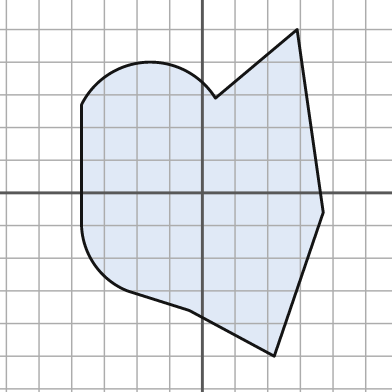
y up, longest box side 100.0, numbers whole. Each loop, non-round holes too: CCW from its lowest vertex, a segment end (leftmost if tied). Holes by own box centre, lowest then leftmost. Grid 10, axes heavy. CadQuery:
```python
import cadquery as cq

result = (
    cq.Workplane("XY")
    .moveTo(22.0, -50.0)
    .lineTo(37.0, -6.0)
    .lineTo(29.0, 50.0)
    .lineTo(4.0, 29.0)
    .threePointArc((-17.0, 40.0), (-37.0, 27.0))
    .lineTo(-37.0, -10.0)
    .threePointArc((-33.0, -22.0), (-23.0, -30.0))
    .lineTo(-4.0, -36.0)
    .close()
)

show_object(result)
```